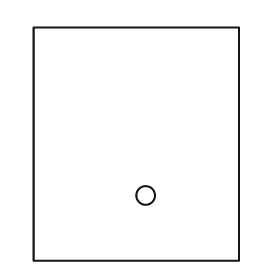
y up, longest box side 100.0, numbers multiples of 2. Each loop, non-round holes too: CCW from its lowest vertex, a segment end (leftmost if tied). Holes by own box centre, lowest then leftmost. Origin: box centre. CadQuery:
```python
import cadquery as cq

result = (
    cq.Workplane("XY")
    .moveTo(-44.0, -50.0)
    .lineTo(44.0, -50.0)
    .lineTo(44.0, 50.0)
    .lineTo(-44.0, 50.0)
    .close()
    .moveTo(4.0, -22.0)
    .circle(4.0)
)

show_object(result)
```